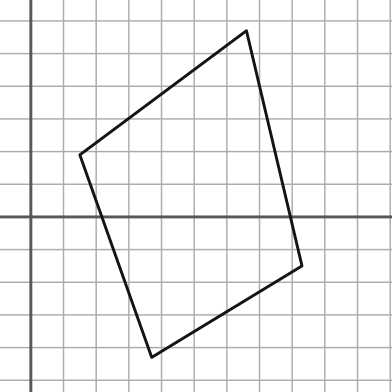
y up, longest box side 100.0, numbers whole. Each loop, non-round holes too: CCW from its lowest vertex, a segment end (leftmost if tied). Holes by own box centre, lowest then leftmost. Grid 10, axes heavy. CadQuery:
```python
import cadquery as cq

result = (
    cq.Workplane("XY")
    .moveTo(37.0, -43.0)
    .lineTo(83.0, -15.0)
    .lineTo(66.0, 57.0)
    .lineTo(15.0, 19.0)
    .close()
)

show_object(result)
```